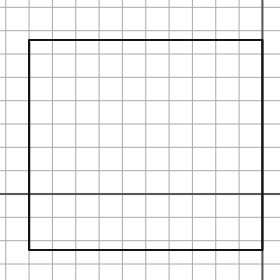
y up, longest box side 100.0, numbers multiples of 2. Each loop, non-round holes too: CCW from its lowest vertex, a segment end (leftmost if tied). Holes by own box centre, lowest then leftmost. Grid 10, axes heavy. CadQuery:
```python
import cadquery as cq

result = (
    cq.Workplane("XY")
    .moveTo(-100.0, -24.0)
    .lineTo(0.0, -24.0)
    .lineTo(0.0, 66.0)
    .lineTo(-100.0, 66.0)
    .close()
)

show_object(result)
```